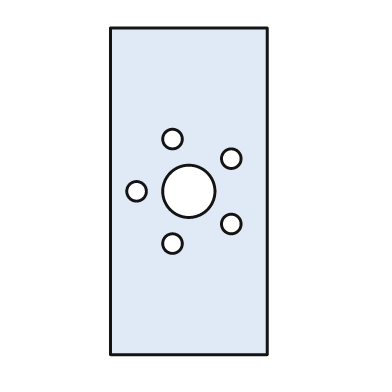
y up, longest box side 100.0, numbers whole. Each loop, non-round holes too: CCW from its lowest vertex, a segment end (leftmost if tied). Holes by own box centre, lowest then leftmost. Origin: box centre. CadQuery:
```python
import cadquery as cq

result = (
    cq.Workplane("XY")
    .moveTo(-24.0, -50.0)
    .lineTo(24.0, -50.0)
    .lineTo(24.0, 50.0)
    .lineTo(-24.0, 50.0)
    .close()
    .moveTo(-5.0, -16.0)
    .circle(3.0)
    .moveTo(13.0, -10.0)
    .circle(3.0)
    .moveTo(-16.0, 0.0)
    .circle(3.0)
    .moveTo(0.0, 0.0)
    .circle(8.0)
    .moveTo(13.0, 10.0)
    .circle(3.0)
    .moveTo(-5.0, 16.0)
    .circle(3.0)
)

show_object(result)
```